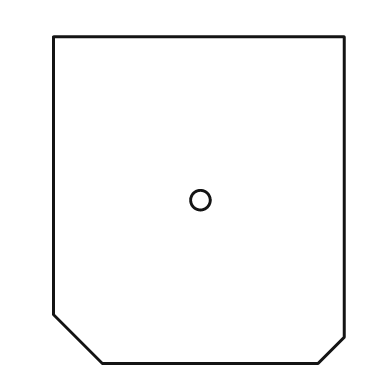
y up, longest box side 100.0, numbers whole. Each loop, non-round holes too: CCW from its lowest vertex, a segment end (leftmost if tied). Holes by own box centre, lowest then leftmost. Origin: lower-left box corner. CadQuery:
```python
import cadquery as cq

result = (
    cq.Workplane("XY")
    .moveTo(15.0, 0.0)
    .lineTo(81.0, 0.0)
    .lineTo(89.0, 8.0)
    .lineTo(89.0, 100.0)
    .lineTo(0.0, 100.0)
    .lineTo(0.0, 15.0)
    .close()
    .moveTo(45.0, 50.0)
    .circle(3.0)
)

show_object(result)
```